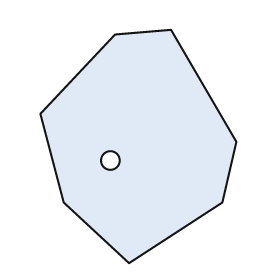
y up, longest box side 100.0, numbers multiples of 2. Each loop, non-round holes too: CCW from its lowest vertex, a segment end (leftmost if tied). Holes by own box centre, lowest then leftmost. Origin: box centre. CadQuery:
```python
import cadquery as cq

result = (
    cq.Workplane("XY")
    .moveTo(-4.0, -50.0)
    .lineTo(36.0, -24.0)
    .lineTo(42.0, 2.0)
    .lineTo(14.0, 50.0)
    .lineTo(-10.0, 48.0)
    .lineTo(-42.0, 14.0)
    .lineTo(-32.0, -24.0)
    .close()
    .moveTo(-12.0, -6.0)
    .circle(4.0)
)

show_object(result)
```